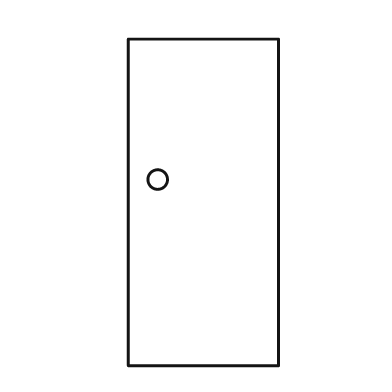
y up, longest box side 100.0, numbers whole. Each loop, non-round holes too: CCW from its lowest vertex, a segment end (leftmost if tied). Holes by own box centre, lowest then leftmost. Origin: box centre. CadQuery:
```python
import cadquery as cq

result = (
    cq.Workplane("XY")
    .moveTo(-23.0, -50.0)
    .lineTo(23.0, -50.0)
    .lineTo(23.0, 50.0)
    .lineTo(-23.0, 50.0)
    .close()
    .moveTo(-14.0, 7.0)
    .circle(3.0)
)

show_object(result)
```